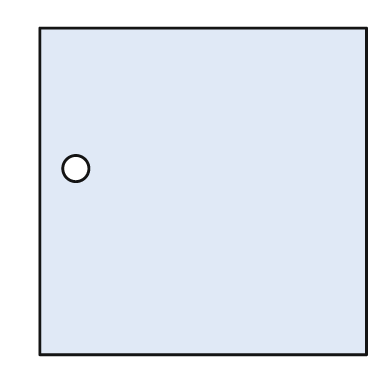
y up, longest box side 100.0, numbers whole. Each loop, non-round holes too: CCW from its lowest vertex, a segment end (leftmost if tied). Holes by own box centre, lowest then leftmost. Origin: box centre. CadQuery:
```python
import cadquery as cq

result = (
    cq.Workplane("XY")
    .moveTo(-50.0, -50.0)
    .lineTo(50.0, -50.0)
    .lineTo(50.0, 50.0)
    .lineTo(-50.0, 50.0)
    .close()
    .moveTo(-39.0, 7.0)
    .circle(4.0)
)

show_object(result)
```